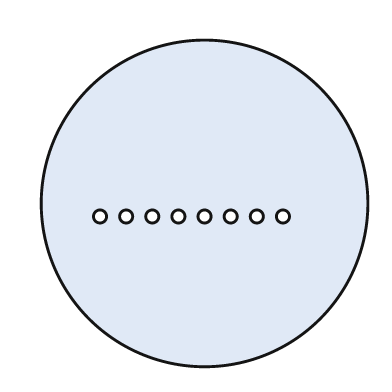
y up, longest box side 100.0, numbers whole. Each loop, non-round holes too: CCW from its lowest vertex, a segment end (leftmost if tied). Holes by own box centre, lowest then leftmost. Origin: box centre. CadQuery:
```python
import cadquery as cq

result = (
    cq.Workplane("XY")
    .moveTo(0.0, 0.0)
    .circle(50.0)
    .moveTo(-32.0, -4.0)
    .circle(2.0)
    .moveTo(-24.0, -4.0)
    .circle(2.0)
    .moveTo(-16.0, -4.0)
    .circle(2.0)
    .moveTo(-8.0, -4.0)
    .circle(2.0)
    .moveTo(0.0, -4.0)
    .circle(2.0)
    .moveTo(8.0, -4.0)
    .circle(2.0)
    .moveTo(16.0, -4.0)
    .circle(2.0)
    .moveTo(24.0, -4.0)
    .circle(2.0)
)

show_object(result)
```